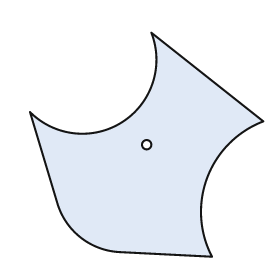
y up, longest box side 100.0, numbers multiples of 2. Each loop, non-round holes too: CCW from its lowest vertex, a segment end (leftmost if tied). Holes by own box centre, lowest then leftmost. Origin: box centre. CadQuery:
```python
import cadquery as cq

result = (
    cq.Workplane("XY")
    .moveTo(28.0, -48.0)
    .threePointArc((26.0, -14.0), (50.0, 10.0))
    .lineTo(2.0, 48.0)
    .threePointArc((-10.0, 10.0), (-50.0, 14.0))
    .lineTo(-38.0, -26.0)
    .threePointArc((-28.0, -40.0), (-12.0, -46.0))
    .close()
    .moveTo(0.0, 0.0)
    .circle(2.0)
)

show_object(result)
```